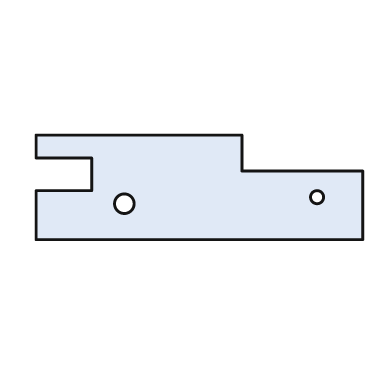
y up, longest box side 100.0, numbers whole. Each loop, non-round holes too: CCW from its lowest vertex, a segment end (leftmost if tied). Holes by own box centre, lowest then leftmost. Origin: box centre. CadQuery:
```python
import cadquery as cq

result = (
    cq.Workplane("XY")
    .moveTo(-50.0, -16.0)
    .lineTo(50.0, -16.0)
    .lineTo(50.0, 5.0)
    .lineTo(13.0, 5.0)
    .lineTo(13.0, 16.0)
    .lineTo(-50.0, 16.0)
    .lineTo(-50.0, 9.0)
    .lineTo(-33.0, 9.0)
    .lineTo(-33.0, -1.0)
    .lineTo(-50.0, -1.0)
    .close()
    .moveTo(-23.0, -5.0)
    .circle(3.0)
    .moveTo(36.0, -3.0)
    .circle(2.0)
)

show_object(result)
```